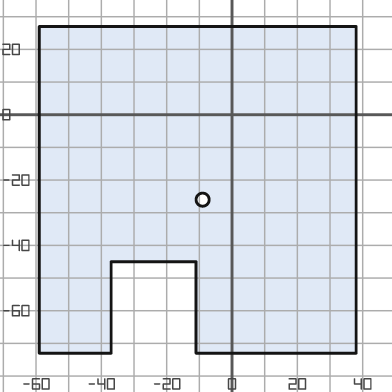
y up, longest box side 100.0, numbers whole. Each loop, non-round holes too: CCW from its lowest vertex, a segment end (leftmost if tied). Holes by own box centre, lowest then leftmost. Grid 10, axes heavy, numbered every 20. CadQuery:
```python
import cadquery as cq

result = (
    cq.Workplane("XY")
    .moveTo(-59.0, -73.0)
    .lineTo(-37.0, -73.0)
    .lineTo(-37.0, -45.0)
    .lineTo(-11.0, -45.0)
    .lineTo(-11.0, -73.0)
    .lineTo(38.0, -73.0)
    .lineTo(38.0, 27.0)
    .lineTo(-59.0, 27.0)
    .close()
    .moveTo(-9.0, -26.0)
    .circle(2.0)
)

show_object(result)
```